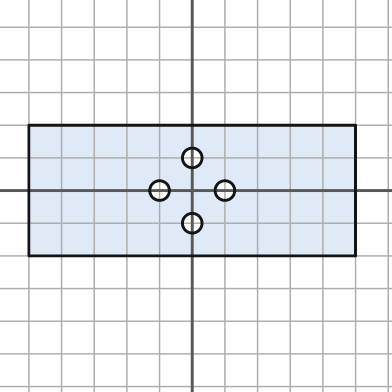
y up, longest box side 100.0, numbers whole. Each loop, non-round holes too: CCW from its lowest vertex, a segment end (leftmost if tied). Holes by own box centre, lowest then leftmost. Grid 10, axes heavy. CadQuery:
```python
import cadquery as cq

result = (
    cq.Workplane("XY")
    .moveTo(-50.0, -20.0)
    .lineTo(50.0, -20.0)
    .lineTo(50.0, 20.0)
    .lineTo(-50.0, 20.0)
    .close()
    .moveTo(0.0, -10.0)
    .circle(3.0)
    .moveTo(-10.0, 0.0)
    .circle(3.0)
    .moveTo(10.0, 0.0)
    .circle(3.0)
    .moveTo(0.0, 10.0)
    .circle(3.0)
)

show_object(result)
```